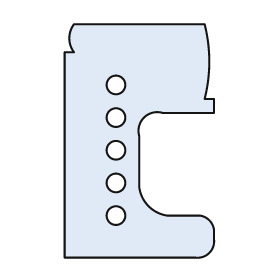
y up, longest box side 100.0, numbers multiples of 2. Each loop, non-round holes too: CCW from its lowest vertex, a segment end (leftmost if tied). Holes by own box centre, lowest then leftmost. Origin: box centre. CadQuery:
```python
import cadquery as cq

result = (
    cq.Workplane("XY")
    .moveTo(-32.0, -50.0)
    .lineTo(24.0, -50.0)
    .threePointArc((30.0, -48.0), (32.0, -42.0))
    .lineTo(32.0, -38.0)
    .threePointArc((30.0, -34.0), (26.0, -32.0))
    .lineTo(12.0, -32.0)
    .threePointArc((4.0, -28.0), (0.0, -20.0))
    .lineTo(0.0, 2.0)
    .threePointArc((2.0, 10.0), (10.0, 12.0))
    .lineTo(32.0, 12.0)
    .lineTo(32.0, 18.0)
    .lineTo(28.0, 18.0)
    .threePointArc((30.0, 34.0), (28.0, 50.0))
    .lineTo(-28.0, 50.0)
    .threePointArc((-30.0, 44.0), (-28.0, 38.0))
    .lineTo(-32.0, 38.0)
    .close()
    .moveTo(-10.0, -32.0)
    .circle(4.0)
    .moveTo(-10.0, -18.0)
    .circle(4.0)
    .moveTo(-10.0, -4.0)
    .circle(4.0)
    .moveTo(-10.0, 10.0)
    .circle(4.0)
    .moveTo(-10.0, 24.0)
    .circle(4.0)
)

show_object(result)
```